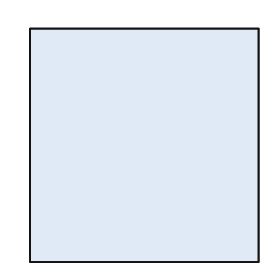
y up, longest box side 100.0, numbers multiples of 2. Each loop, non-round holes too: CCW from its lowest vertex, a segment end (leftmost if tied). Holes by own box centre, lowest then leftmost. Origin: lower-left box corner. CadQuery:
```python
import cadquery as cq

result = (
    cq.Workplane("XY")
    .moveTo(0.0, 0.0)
    .lineTo(98.0, 0.0)
    .lineTo(98.0, 100.0)
    .lineTo(0.0, 100.0)
    .close()
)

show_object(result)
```